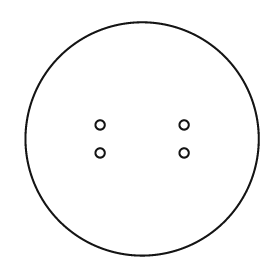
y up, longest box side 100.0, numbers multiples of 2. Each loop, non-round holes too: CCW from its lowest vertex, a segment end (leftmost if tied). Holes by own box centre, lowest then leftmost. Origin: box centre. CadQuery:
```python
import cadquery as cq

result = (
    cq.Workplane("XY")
    .moveTo(0.0, 0.0)
    .circle(50.0)
    .moveTo(-18.0, -6.0)
    .circle(2.0)
    .moveTo(18.0, -6.0)
    .circle(2.0)
    .moveTo(-18.0, 6.0)
    .circle(2.0)
    .moveTo(18.0, 6.0)
    .circle(2.0)
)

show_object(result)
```